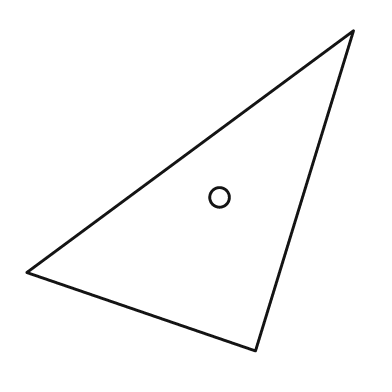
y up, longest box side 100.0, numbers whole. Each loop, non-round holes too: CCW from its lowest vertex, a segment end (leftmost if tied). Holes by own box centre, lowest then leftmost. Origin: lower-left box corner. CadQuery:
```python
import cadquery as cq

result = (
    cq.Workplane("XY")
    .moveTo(70.0, 0.0)
    .lineTo(100.0, 98.0)
    .lineTo(0.0, 24.0)
    .close()
    .moveTo(59.0, 47.0)
    .circle(3.0)
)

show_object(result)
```